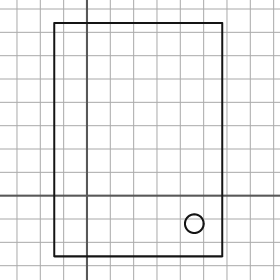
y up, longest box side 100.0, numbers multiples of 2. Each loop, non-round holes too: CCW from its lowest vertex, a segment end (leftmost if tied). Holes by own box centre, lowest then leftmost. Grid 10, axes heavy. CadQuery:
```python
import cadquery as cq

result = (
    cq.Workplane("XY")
    .moveTo(-14.0, -26.0)
    .lineTo(58.0, -26.0)
    .lineTo(58.0, 74.0)
    .lineTo(-14.0, 74.0)
    .close()
    .moveTo(46.0, -12.0)
    .circle(4.0)
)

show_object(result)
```